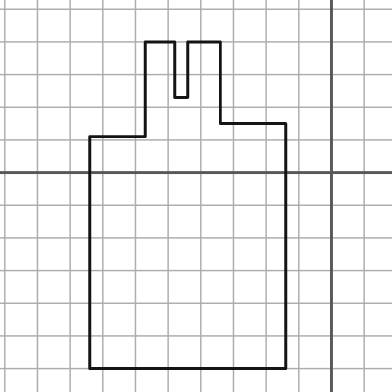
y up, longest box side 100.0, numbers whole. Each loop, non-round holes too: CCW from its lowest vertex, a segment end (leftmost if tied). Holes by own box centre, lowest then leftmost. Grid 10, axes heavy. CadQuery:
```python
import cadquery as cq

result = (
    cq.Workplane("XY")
    .moveTo(-74.0, -60.0)
    .lineTo(-14.0, -60.0)
    .lineTo(-14.0, 15.0)
    .lineTo(-34.0, 15.0)
    .lineTo(-34.0, 40.0)
    .lineTo(-44.0, 40.0)
    .lineTo(-44.0, 23.0)
    .lineTo(-48.0, 23.0)
    .lineTo(-48.0, 40.0)
    .lineTo(-57.0, 40.0)
    .lineTo(-57.0, 11.0)
    .lineTo(-74.0, 11.0)
    .close()
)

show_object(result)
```